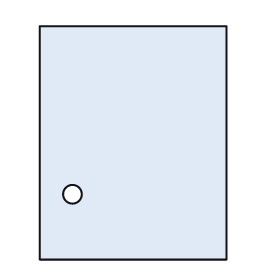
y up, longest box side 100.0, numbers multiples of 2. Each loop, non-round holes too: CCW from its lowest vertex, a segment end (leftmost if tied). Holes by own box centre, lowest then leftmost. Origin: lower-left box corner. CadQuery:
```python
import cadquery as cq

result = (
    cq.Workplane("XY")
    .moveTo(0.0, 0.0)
    .lineTo(80.0, 0.0)
    .lineTo(80.0, 100.0)
    .lineTo(0.0, 100.0)
    .close()
    .moveTo(14.0, 28.0)
    .circle(4.0)
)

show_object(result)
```